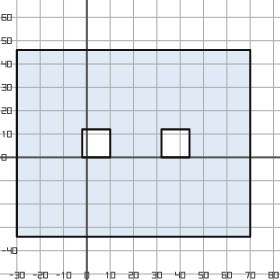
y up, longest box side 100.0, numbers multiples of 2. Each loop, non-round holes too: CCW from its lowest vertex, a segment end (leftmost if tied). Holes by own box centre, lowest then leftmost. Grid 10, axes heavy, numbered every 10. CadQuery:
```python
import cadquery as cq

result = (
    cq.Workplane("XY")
    .moveTo(-30.0, -34.0)
    .lineTo(70.0, -34.0)
    .lineTo(70.0, 46.0)
    .lineTo(-30.0, 46.0)
    .close()
    .moveTo(-2.0, 0.0)
    .lineTo(10.0, 0.0)
    .lineTo(10.0, 12.0)
    .lineTo(-2.0, 12.0)
    .close()
    .moveTo(32.0, 0.0)
    .lineTo(44.0, 0.0)
    .lineTo(44.0, 12.0)
    .lineTo(32.0, 12.0)
    .close()
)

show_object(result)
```